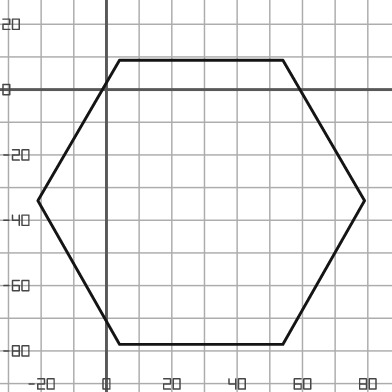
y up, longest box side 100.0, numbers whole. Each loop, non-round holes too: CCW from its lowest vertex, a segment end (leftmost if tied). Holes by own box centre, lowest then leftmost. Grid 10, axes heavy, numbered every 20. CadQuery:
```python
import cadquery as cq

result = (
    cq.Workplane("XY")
    .moveTo(4.0, -78.0)
    .lineTo(54.0, -78.0)
    .lineTo(79.0, -34.0)
    .lineTo(54.0, 9.0)
    .lineTo(4.0, 9.0)
    .lineTo(-21.0, -34.0)
    .close()
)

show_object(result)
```